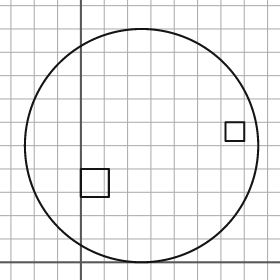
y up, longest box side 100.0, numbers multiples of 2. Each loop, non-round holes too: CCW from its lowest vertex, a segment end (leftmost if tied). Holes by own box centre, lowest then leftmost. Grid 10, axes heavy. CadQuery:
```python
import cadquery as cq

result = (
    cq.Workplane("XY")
    .moveTo(26.0, 50.0)
    .circle(50.0)
    .moveTo(0.0, 28.0)
    .lineTo(12.0, 28.0)
    .lineTo(12.0, 40.0)
    .lineTo(0.0, 40.0)
    .close()
    .moveTo(62.0, 52.0)
    .lineTo(70.0, 52.0)
    .lineTo(70.0, 60.0)
    .lineTo(62.0, 60.0)
    .close()
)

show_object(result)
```